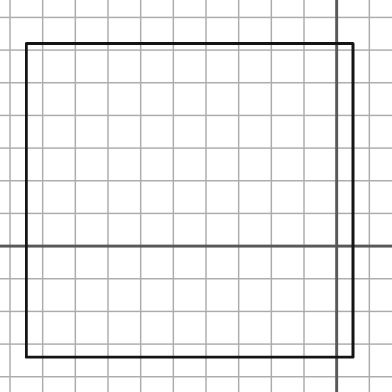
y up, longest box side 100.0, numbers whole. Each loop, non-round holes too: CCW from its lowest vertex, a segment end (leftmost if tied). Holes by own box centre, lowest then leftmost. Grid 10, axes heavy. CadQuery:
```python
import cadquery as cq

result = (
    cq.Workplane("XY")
    .moveTo(-95.0, -34.0)
    .lineTo(5.0, -34.0)
    .lineTo(5.0, 62.0)
    .lineTo(-95.0, 62.0)
    .close()
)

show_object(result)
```